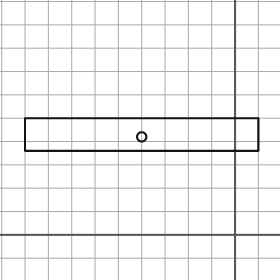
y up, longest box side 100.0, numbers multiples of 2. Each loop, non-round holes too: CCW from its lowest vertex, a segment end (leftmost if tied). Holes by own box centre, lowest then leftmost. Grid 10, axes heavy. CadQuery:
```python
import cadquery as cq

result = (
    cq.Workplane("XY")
    .moveTo(-90.0, 36.0)
    .lineTo(10.0, 36.0)
    .lineTo(10.0, 50.0)
    .lineTo(-90.0, 50.0)
    .close()
    .moveTo(-40.0, 42.0)
    .circle(2.0)
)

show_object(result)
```